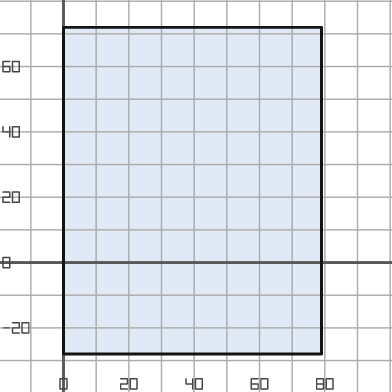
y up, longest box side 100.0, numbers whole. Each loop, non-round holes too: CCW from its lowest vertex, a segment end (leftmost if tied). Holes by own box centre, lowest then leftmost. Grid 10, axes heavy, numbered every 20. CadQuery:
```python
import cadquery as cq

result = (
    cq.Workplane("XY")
    .moveTo(0.0, -28.0)
    .lineTo(79.0, -28.0)
    .lineTo(79.0, 72.0)
    .lineTo(0.0, 72.0)
    .close()
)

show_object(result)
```